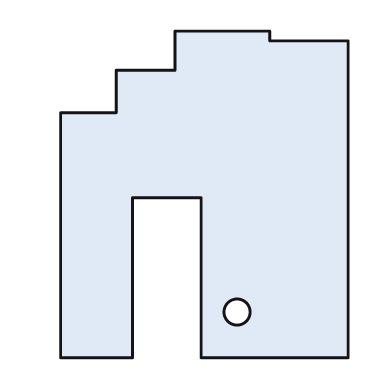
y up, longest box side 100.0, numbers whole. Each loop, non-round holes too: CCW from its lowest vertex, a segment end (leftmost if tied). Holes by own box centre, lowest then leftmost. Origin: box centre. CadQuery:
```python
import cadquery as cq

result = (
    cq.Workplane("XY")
    .moveTo(-44.0, -50.0)
    .lineTo(-22.0, -50.0)
    .lineTo(-22.0, -1.0)
    .lineTo(-1.0, -1.0)
    .lineTo(-1.0, -50.0)
    .lineTo(44.0, -50.0)
    .lineTo(44.0, 47.0)
    .lineTo(20.0, 47.0)
    .lineTo(20.0, 50.0)
    .lineTo(-9.0, 50.0)
    .lineTo(-9.0, 38.0)
    .lineTo(-27.0, 38.0)
    .lineTo(-27.0, 25.0)
    .lineTo(-44.0, 25.0)
    .close()
    .moveTo(10.0, -36.0)
    .circle(4.0)
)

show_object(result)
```